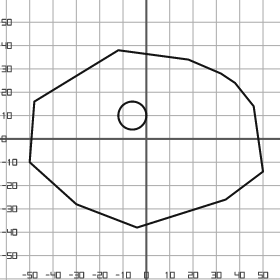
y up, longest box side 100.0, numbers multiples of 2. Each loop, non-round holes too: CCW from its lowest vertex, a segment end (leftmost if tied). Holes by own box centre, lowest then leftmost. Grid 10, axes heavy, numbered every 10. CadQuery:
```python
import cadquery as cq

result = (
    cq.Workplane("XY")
    .moveTo(-4.0, -38.0)
    .lineTo(34.0, -26.0)
    .lineTo(50.0, -14.0)
    .lineTo(46.0, 14.0)
    .lineTo(38.0, 24.0)
    .lineTo(32.0, 28.0)
    .lineTo(18.0, 34.0)
    .lineTo(-12.0, 38.0)
    .lineTo(-48.0, 16.0)
    .lineTo(-50.0, -10.0)
    .lineTo(-30.0, -28.0)
    .close()
    .moveTo(-6.0, 10.0)
    .circle(6.0)
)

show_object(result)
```